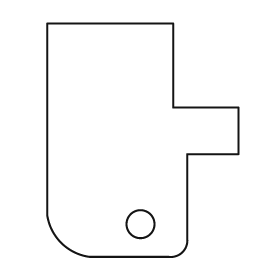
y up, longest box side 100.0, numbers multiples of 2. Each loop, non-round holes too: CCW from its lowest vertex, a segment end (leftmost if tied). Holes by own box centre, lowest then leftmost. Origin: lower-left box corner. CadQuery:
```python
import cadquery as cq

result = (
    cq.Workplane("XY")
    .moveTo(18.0, 0.0)
    .lineTo(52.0, 0.0)
    .threePointArc((58.0, 2.0), (60.0, 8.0))
    .lineTo(60.0, 44.0)
    .lineTo(82.0, 44.0)
    .lineTo(82.0, 64.0)
    .lineTo(54.0, 64.0)
    .lineTo(54.0, 100.0)
    .lineTo(0.0, 100.0)
    .lineTo(0.0, 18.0)
    .threePointArc((6.0, 6.0), (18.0, 0.0))
    .close()
    .moveTo(40.0, 14.0)
    .circle(6.0)
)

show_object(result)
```